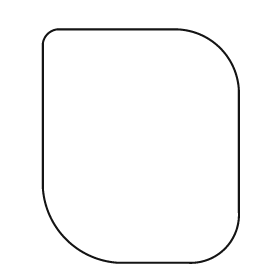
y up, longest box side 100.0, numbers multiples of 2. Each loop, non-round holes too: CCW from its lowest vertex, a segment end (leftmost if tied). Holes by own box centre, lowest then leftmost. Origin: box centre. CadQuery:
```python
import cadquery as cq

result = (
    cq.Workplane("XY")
    .moveTo(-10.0, -50.0)
    .lineTo(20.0, -50.0)
    .threePointArc((36.0, -44.0), (42.0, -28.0))
    .lineTo(42.0, 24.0)
    .threePointArc((34.0, 42.0), (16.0, 50.0))
    .lineTo(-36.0, 50.0)
    .threePointArc((-40.0, 48.0), (-42.0, 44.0))
    .lineTo(-42.0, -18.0)
    .threePointArc((-32.0, -40.0), (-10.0, -50.0))
    .close()
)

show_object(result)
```